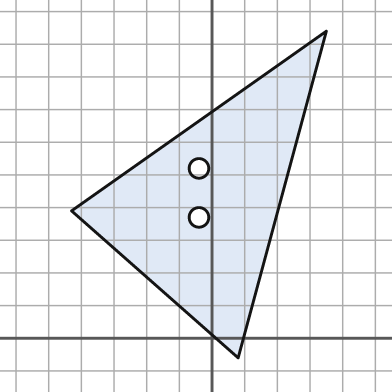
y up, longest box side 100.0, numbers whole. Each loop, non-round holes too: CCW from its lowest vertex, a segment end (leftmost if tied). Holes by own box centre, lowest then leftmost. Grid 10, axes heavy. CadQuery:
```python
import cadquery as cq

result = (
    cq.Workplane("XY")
    .moveTo(8.0, -6.0)
    .lineTo(35.0, 94.0)
    .lineTo(-43.0, 39.0)
    .close()
    .moveTo(-4.0, 37.0)
    .circle(3.0)
    .moveTo(-4.0, 52.0)
    .circle(3.0)
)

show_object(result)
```